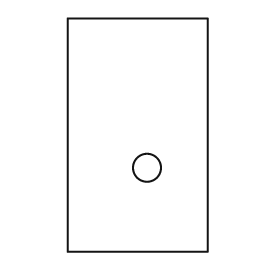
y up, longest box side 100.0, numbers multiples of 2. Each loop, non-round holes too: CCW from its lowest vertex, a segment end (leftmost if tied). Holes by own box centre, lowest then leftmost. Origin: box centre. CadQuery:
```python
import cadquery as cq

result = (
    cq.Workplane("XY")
    .moveTo(-30.0, -50.0)
    .lineTo(30.0, -50.0)
    .lineTo(30.0, 50.0)
    .lineTo(-30.0, 50.0)
    .close()
    .moveTo(4.0, -14.0)
    .circle(6.0)
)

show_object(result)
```